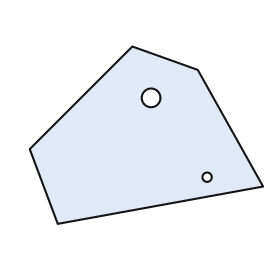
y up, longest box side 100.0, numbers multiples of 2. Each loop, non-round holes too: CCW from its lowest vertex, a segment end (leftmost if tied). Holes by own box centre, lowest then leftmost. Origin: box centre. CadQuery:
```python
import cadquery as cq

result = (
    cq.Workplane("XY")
    .moveTo(-38.0, -38.0)
    .lineTo(50.0, -22.0)
    .lineTo(22.0, 28.0)
    .lineTo(-6.0, 38.0)
    .lineTo(-50.0, -6.0)
    .close()
    .moveTo(26.0, -18.0)
    .circle(2.0)
    .moveTo(2.0, 16.0)
    .circle(4.0)
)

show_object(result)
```